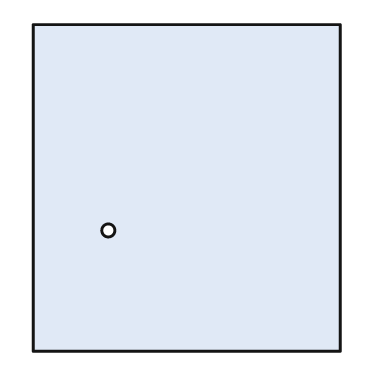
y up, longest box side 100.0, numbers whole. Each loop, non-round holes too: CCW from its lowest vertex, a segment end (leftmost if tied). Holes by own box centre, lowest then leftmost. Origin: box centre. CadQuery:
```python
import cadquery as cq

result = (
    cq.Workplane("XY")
    .moveTo(-47.0, -50.0)
    .lineTo(47.0, -50.0)
    .lineTo(47.0, 50.0)
    .lineTo(-47.0, 50.0)
    .close()
    .moveTo(-24.0, -13.0)
    .circle(2.0)
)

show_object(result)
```